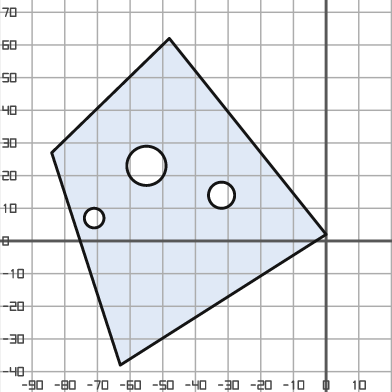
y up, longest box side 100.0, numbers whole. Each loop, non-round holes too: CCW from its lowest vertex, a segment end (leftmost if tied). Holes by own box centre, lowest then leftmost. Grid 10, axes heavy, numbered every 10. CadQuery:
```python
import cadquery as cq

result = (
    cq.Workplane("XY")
    .moveTo(-63.0, -38.0)
    .lineTo(0.0, 2.0)
    .lineTo(-48.0, 62.0)
    .lineTo(-84.0, 27.0)
    .close()
    .moveTo(-71.0, 7.0)
    .circle(3.0)
    .moveTo(-32.0, 14.0)
    .circle(4.0)
    .moveTo(-55.0, 23.0)
    .circle(6.0)
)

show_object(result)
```